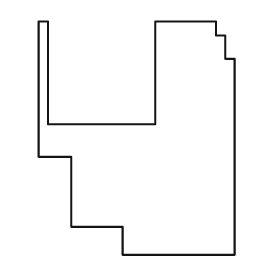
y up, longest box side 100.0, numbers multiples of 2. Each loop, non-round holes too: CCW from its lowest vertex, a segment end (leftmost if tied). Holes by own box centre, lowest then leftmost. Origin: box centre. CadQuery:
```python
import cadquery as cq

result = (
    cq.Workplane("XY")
    .moveTo(-6.0, -50.0)
    .lineTo(42.0, -50.0)
    .lineTo(42.0, 34.0)
    .lineTo(38.0, 34.0)
    .lineTo(38.0, 44.0)
    .lineTo(34.0, 44.0)
    .lineTo(34.0, 50.0)
    .lineTo(8.0, 50.0)
    .lineTo(8.0, 6.0)
    .lineTo(-38.0, 6.0)
    .lineTo(-38.0, 50.0)
    .lineTo(-42.0, 50.0)
    .lineTo(-42.0, -8.0)
    .lineTo(-28.0, -8.0)
    .lineTo(-28.0, -38.0)
    .lineTo(-6.0, -38.0)
    .close()
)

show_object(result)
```